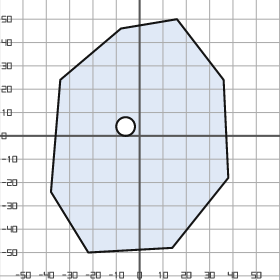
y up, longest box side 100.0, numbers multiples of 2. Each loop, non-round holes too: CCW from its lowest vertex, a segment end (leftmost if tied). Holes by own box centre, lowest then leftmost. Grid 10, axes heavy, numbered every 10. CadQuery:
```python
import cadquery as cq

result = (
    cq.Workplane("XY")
    .moveTo(-22.0, -50.0)
    .lineTo(14.0, -48.0)
    .lineTo(38.0, -18.0)
    .lineTo(36.0, 24.0)
    .lineTo(16.0, 50.0)
    .lineTo(-8.0, 46.0)
    .lineTo(-34.0, 24.0)
    .lineTo(-38.0, -24.0)
    .close()
    .moveTo(-6.0, 4.0)
    .circle(4.0)
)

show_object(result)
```